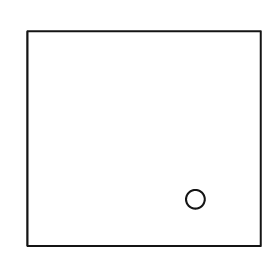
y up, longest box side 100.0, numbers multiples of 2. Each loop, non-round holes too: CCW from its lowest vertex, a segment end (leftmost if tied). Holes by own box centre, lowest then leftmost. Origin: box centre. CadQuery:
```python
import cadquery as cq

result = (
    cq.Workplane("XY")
    .moveTo(-50.0, -46.0)
    .lineTo(50.0, -46.0)
    .lineTo(50.0, 46.0)
    .lineTo(-50.0, 46.0)
    .close()
    .moveTo(22.0, -26.0)
    .circle(4.0)
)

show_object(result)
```